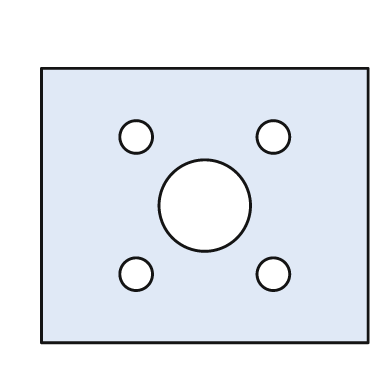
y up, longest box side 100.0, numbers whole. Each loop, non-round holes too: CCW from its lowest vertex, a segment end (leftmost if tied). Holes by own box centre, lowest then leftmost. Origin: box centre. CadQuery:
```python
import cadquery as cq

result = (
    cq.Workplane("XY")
    .moveTo(-50.0, -42.0)
    .lineTo(50.0, -42.0)
    .lineTo(50.0, 42.0)
    .lineTo(-50.0, 42.0)
    .close()
    .moveTo(-21.0, -21.0)
    .circle(5.0)
    .moveTo(21.0, -21.0)
    .circle(5.0)
    .moveTo(0.0, 0.0)
    .circle(14.0)
    .moveTo(-21.0, 21.0)
    .circle(5.0)
    .moveTo(21.0, 21.0)
    .circle(5.0)
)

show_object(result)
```